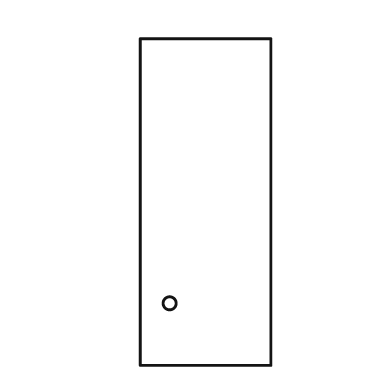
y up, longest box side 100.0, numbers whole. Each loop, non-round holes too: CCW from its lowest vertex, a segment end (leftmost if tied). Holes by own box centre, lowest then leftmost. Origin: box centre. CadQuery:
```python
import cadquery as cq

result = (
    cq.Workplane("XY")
    .moveTo(-20.0, -50.0)
    .lineTo(20.0, -50.0)
    .lineTo(20.0, 50.0)
    .lineTo(-20.0, 50.0)
    .close()
    .moveTo(-11.0, -31.0)
    .circle(2.0)
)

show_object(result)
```